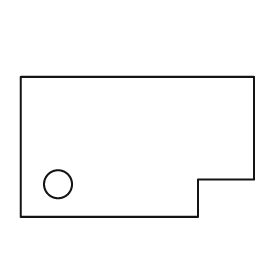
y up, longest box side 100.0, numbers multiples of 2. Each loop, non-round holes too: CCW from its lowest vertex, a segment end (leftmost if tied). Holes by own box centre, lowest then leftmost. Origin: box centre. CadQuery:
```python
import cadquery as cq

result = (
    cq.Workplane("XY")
    .moveTo(-50.0, -30.0)
    .lineTo(26.0, -30.0)
    .lineTo(26.0, -14.0)
    .lineTo(50.0, -14.0)
    .lineTo(50.0, 30.0)
    .lineTo(-50.0, 30.0)
    .close()
    .moveTo(-34.0, -16.0)
    .circle(6.0)
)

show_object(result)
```